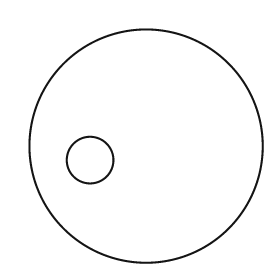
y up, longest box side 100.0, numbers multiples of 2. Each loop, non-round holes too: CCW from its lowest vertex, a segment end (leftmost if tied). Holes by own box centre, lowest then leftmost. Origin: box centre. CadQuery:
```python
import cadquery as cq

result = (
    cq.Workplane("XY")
    .moveTo(0.0, 0.0)
    .circle(50.0)
    .moveTo(-24.0, -6.0)
    .circle(10.0)
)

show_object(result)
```